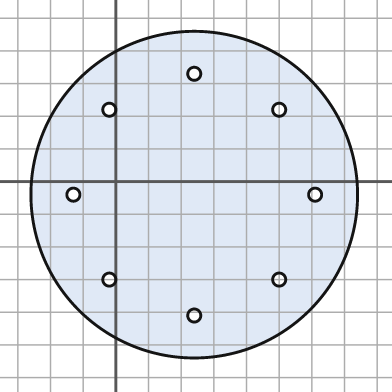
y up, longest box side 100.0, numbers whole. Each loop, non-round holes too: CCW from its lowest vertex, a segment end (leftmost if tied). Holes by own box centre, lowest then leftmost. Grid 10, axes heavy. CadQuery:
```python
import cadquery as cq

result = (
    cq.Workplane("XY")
    .moveTo(24.0, -4.0)
    .circle(50.0)
    .moveTo(24.0, -41.0)
    .circle(2.0)
    .moveTo(-2.0, -30.0)
    .circle(2.0)
    .moveTo(50.0, -30.0)
    .circle(2.0)
    .moveTo(-13.0, -4.0)
    .circle(2.0)
    .moveTo(61.0, -4.0)
    .circle(2.0)
    .moveTo(-2.0, 22.0)
    .circle(2.0)
    .moveTo(50.0, 22.0)
    .circle(2.0)
    .moveTo(24.0, 33.0)
    .circle(2.0)
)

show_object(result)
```